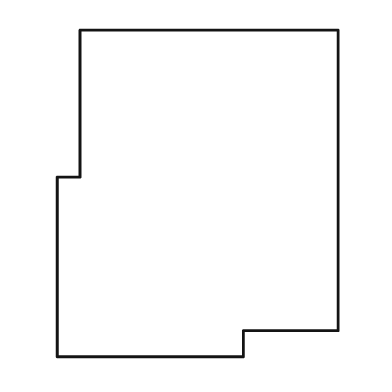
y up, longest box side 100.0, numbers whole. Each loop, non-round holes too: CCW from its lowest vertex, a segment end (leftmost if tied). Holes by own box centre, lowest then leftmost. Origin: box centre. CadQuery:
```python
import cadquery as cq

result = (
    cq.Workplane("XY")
    .moveTo(-43.0, -50.0)
    .lineTo(14.0, -50.0)
    .lineTo(14.0, -42.0)
    .lineTo(43.0, -42.0)
    .lineTo(43.0, 50.0)
    .lineTo(-36.0, 50.0)
    .lineTo(-36.0, 5.0)
    .lineTo(-43.0, 5.0)
    .close()
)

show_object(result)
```